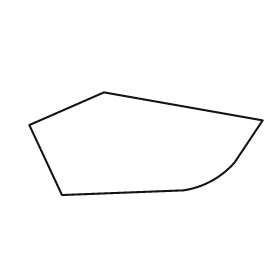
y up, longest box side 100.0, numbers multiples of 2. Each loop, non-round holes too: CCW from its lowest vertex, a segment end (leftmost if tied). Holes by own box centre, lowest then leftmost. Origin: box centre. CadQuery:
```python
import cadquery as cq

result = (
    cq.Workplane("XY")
    .moveTo(-36.0, -22.0)
    .lineTo(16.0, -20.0)
    .threePointArc((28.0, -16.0), (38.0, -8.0))
    .lineTo(50.0, 10.0)
    .lineTo(-18.0, 22.0)
    .lineTo(-50.0, 8.0)
    .close()
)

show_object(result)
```